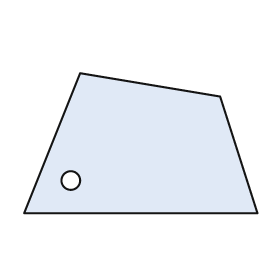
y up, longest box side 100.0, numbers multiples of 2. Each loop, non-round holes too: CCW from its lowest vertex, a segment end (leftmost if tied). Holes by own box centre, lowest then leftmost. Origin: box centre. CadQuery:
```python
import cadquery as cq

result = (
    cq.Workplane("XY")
    .moveTo(-50.0, -30.0)
    .lineTo(50.0, -30.0)
    .lineTo(34.0, 20.0)
    .lineTo(-26.0, 30.0)
    .close()
    .moveTo(-30.0, -16.0)
    .circle(4.0)
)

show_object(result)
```